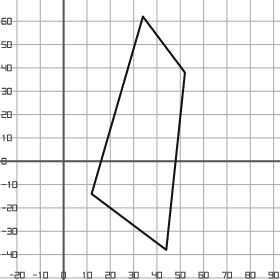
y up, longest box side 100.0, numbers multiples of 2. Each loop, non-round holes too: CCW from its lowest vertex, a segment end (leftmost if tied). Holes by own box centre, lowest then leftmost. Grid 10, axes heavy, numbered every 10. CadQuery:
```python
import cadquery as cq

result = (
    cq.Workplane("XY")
    .moveTo(44.0, -38.0)
    .lineTo(52.0, 38.0)
    .lineTo(34.0, 62.0)
    .lineTo(12.0, -14.0)
    .close()
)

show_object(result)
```